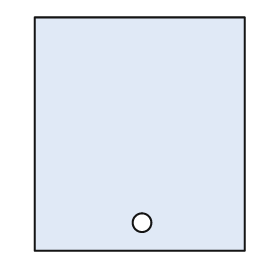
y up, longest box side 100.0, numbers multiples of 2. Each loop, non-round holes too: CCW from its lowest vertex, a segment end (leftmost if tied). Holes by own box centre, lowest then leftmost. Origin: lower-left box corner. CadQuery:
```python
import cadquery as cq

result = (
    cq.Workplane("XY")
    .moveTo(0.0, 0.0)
    .lineTo(90.0, 0.0)
    .lineTo(90.0, 100.0)
    .lineTo(0.0, 100.0)
    .close()
    .moveTo(46.0, 12.0)
    .circle(4.0)
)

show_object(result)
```